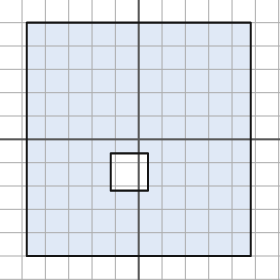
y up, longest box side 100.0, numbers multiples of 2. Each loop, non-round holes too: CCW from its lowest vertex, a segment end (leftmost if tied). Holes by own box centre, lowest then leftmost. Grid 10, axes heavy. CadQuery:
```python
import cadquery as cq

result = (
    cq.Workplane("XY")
    .moveTo(-48.0, -50.0)
    .lineTo(48.0, -50.0)
    .lineTo(48.0, 50.0)
    .lineTo(-48.0, 50.0)
    .close()
    .moveTo(-12.0, -22.0)
    .lineTo(4.0, -22.0)
    .lineTo(4.0, -6.0)
    .lineTo(-12.0, -6.0)
    .close()
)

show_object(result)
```